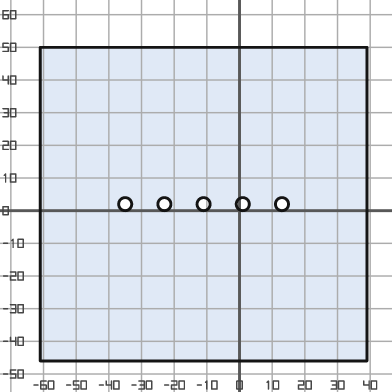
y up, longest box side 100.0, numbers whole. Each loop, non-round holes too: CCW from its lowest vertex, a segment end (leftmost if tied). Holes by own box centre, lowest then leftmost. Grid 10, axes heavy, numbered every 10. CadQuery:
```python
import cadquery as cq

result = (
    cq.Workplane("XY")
    .moveTo(-61.0, -46.0)
    .lineTo(39.0, -46.0)
    .lineTo(39.0, 50.0)
    .lineTo(-61.0, 50.0)
    .close()
    .moveTo(-35.0, 2.0)
    .circle(2.0)
    .moveTo(-23.0, 2.0)
    .circle(2.0)
    .moveTo(-11.0, 2.0)
    .circle(2.0)
    .moveTo(1.0, 2.0)
    .circle(2.0)
    .moveTo(13.0, 2.0)
    .circle(2.0)
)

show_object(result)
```